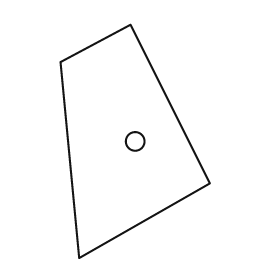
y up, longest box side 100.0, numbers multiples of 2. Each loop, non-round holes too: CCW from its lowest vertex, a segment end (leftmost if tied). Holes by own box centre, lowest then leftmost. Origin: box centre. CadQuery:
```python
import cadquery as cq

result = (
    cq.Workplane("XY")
    .moveTo(-24.0, -50.0)
    .lineTo(32.0, -18.0)
    .lineTo(-2.0, 50.0)
    .lineTo(-32.0, 34.0)
    .close()
    .moveTo(0.0, 0.0)
    .circle(4.0)
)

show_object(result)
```